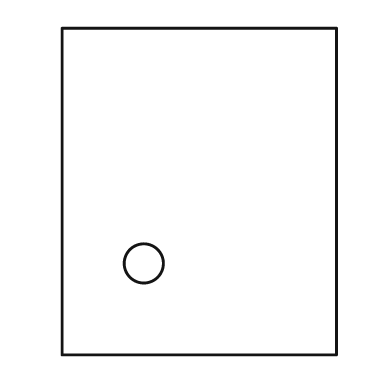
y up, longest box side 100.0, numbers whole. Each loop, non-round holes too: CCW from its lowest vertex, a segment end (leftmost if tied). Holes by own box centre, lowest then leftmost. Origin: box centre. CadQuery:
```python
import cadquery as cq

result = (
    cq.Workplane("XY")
    .moveTo(-42.0, -50.0)
    .lineTo(42.0, -50.0)
    .lineTo(42.0, 50.0)
    .lineTo(-42.0, 50.0)
    .close()
    .moveTo(-17.0, -22.0)
    .circle(6.0)
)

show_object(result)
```